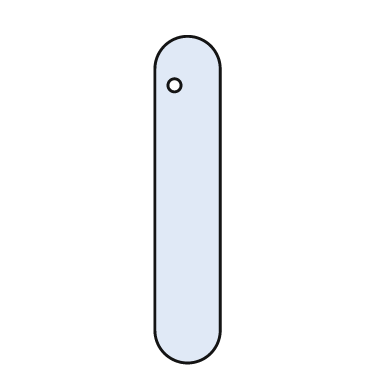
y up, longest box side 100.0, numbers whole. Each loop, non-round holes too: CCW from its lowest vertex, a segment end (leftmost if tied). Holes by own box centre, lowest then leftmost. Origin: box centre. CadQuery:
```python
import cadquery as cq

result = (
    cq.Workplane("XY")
    .moveTo(-10.0, -40.0)
    .threePointArc((0.0, -50.0), (10.0, -40.0))
    .lineTo(10.0, 40.0)
    .threePointArc((0.0, 50.0), (-10.0, 40.0))
    .close()
    .moveTo(-4.0, 35.0)
    .circle(2.0)
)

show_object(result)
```